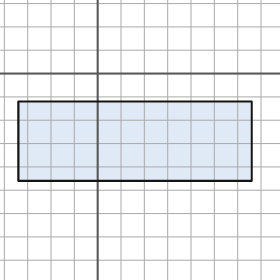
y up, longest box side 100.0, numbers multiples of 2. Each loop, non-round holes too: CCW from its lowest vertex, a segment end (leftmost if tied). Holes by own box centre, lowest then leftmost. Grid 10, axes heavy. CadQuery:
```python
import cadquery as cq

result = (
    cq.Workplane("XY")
    .moveTo(-34.0, -46.0)
    .lineTo(66.0, -46.0)
    .lineTo(66.0, -12.0)
    .lineTo(-34.0, -12.0)
    .close()
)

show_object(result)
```